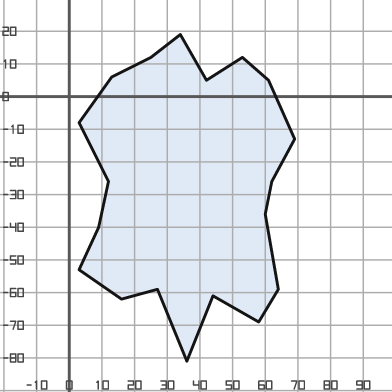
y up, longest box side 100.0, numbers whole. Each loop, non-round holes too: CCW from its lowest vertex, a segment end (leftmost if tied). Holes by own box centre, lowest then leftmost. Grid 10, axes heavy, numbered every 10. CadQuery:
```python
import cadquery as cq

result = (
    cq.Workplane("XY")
    .moveTo(36.0, -81.0)
    .lineTo(44.0, -61.0)
    .lineTo(58.0, -69.0)
    .lineTo(64.0, -59.0)
    .lineTo(60.0, -36.0)
    .lineTo(62.0, -26.0)
    .lineTo(69.0, -13.0)
    .lineTo(61.0, 5.0)
    .lineTo(53.0, 12.0)
    .lineTo(42.0, 5.0)
    .lineTo(34.0, 19.0)
    .lineTo(25.0, 12.0)
    .lineTo(13.0, 6.0)
    .lineTo(3.0, -8.0)
    .lineTo(12.0, -26.0)
    .lineTo(9.0, -40.0)
    .lineTo(3.0, -53.0)
    .lineTo(16.0, -62.0)
    .lineTo(27.0, -59.0)
    .close()
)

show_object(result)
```